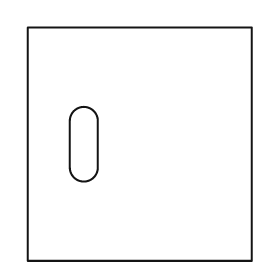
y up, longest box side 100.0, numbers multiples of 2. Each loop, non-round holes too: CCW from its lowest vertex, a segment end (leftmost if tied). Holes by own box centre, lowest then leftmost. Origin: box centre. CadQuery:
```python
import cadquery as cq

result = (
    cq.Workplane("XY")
    .moveTo(-48.0, -50.0)
    .lineTo(48.0, -50.0)
    .lineTo(48.0, 50.0)
    .lineTo(-48.0, 50.0)
    .close()
    .moveTo(-30.0, -10.0)
    .threePointArc((-24.0, -16.0), (-18.0, -10.0))
    .lineTo(-18.0, 10.0)
    .threePointArc((-24.0, 16.0), (-30.0, 10.0))
    .close()
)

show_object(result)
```